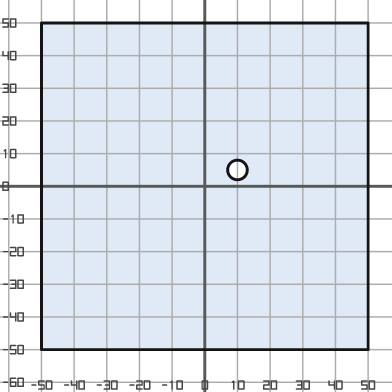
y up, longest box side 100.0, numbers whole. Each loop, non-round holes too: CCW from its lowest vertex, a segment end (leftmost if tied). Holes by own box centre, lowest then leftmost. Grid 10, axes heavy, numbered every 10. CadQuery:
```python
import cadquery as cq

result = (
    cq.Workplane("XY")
    .moveTo(-50.0, -50.0)
    .lineTo(50.0, -50.0)
    .lineTo(50.0, 50.0)
    .lineTo(-50.0, 50.0)
    .close()
    .moveTo(10.0, 5.0)
    .circle(3.0)
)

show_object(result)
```